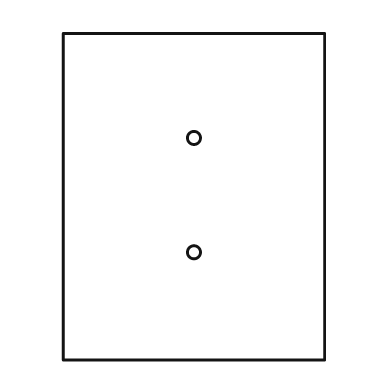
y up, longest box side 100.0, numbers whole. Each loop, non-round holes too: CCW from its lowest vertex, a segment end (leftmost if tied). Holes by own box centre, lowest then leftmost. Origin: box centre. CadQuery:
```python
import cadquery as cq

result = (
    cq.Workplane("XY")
    .moveTo(-40.0, -50.0)
    .lineTo(40.0, -50.0)
    .lineTo(40.0, 50.0)
    .lineTo(-40.0, 50.0)
    .close()
    .moveTo(0.0, -17.0)
    .circle(2.0)
    .moveTo(0.0, 18.0)
    .circle(2.0)
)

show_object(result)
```